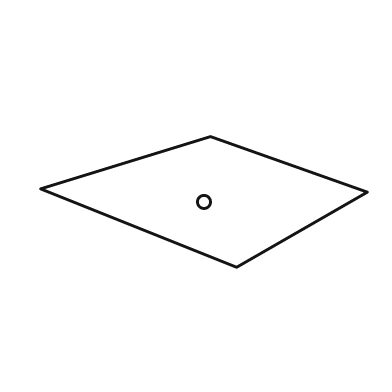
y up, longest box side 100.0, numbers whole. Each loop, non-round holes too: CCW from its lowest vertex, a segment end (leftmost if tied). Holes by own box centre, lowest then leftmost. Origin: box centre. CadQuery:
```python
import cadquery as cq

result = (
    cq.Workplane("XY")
    .moveTo(10.0, -20.0)
    .lineTo(50.0, 3.0)
    .lineTo(2.0, 20.0)
    .lineTo(-50.0, 4.0)
    .close()
    .moveTo(0.0, 0.0)
    .circle(2.0)
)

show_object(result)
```